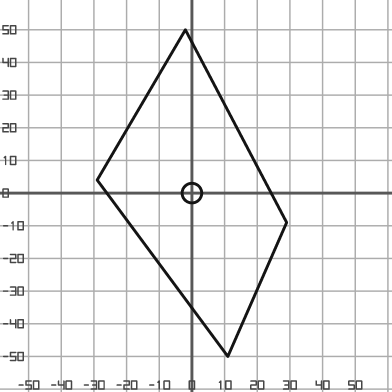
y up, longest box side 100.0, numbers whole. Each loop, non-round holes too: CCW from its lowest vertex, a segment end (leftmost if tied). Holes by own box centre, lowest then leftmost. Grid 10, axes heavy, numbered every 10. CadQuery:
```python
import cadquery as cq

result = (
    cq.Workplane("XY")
    .moveTo(11.0, -50.0)
    .lineTo(29.0, -9.0)
    .lineTo(-2.0, 50.0)
    .lineTo(-29.0, 4.0)
    .close()
    .moveTo(0.0, 0.0)
    .circle(3.0)
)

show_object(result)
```